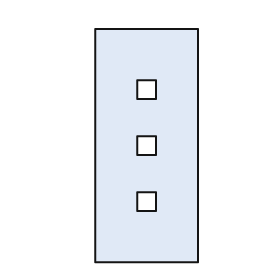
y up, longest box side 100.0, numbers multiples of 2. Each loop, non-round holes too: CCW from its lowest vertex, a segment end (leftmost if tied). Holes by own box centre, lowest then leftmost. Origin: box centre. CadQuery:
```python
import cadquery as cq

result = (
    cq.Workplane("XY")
    .moveTo(-22.0, -50.0)
    .lineTo(22.0, -50.0)
    .lineTo(22.0, 50.0)
    .lineTo(-22.0, 50.0)
    .close()
    .moveTo(-4.0, -28.0)
    .lineTo(4.0, -28.0)
    .lineTo(4.0, -20.0)
    .lineTo(-4.0, -20.0)
    .close()
    .moveTo(-4.0, -4.0)
    .lineTo(4.0, -4.0)
    .lineTo(4.0, 4.0)
    .lineTo(-4.0, 4.0)
    .close()
    .moveTo(-4.0, 20.0)
    .lineTo(4.0, 20.0)
    .lineTo(4.0, 28.0)
    .lineTo(-4.0, 28.0)
    .close()
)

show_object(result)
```